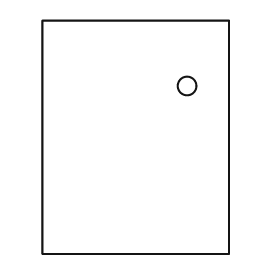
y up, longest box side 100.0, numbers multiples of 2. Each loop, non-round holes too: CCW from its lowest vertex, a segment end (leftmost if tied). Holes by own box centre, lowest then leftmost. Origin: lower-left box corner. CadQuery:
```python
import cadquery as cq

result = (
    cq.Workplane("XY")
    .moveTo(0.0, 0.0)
    .lineTo(80.0, 0.0)
    .lineTo(80.0, 100.0)
    .lineTo(0.0, 100.0)
    .close()
    .moveTo(62.0, 72.0)
    .circle(4.0)
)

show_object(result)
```